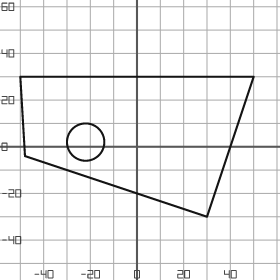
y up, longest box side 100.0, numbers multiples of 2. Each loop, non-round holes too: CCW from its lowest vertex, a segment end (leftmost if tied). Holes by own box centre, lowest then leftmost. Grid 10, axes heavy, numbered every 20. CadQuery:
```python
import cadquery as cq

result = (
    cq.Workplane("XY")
    .moveTo(30.0, -30.0)
    .lineTo(50.0, 30.0)
    .lineTo(-50.0, 30.0)
    .lineTo(-48.0, -4.0)
    .close()
    .moveTo(-22.0, 2.0)
    .circle(8.0)
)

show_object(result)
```